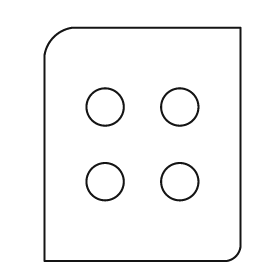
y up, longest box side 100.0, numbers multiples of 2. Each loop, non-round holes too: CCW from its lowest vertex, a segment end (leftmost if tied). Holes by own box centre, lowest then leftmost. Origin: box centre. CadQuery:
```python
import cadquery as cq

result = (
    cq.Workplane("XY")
    .moveTo(-42.0, -50.0)
    .lineTo(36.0, -50.0)
    .threePointArc((40.0, -48.0), (42.0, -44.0))
    .lineTo(42.0, 50.0)
    .lineTo(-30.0, 50.0)
    .threePointArc((-38.0, 46.0), (-42.0, 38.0))
    .close()
    .moveTo(-16.0, -16.0)
    .circle(8.0)
    .moveTo(16.0, -16.0)
    .circle(8.0)
    .moveTo(-16.0, 16.0)
    .circle(8.0)
    .moveTo(16.0, 16.0)
    .circle(8.0)
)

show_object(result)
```